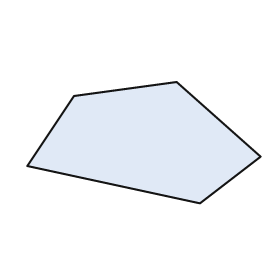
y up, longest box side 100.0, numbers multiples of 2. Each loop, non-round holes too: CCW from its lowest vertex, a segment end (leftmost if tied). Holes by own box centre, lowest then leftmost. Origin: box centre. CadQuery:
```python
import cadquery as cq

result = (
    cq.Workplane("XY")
    .moveTo(24.0, -26.0)
    .lineTo(50.0, -6.0)
    .lineTo(14.0, 26.0)
    .lineTo(-30.0, 20.0)
    .lineTo(-50.0, -10.0)
    .close()
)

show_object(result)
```